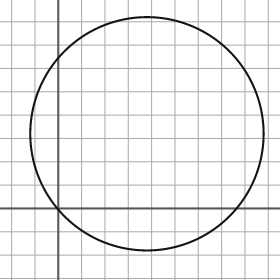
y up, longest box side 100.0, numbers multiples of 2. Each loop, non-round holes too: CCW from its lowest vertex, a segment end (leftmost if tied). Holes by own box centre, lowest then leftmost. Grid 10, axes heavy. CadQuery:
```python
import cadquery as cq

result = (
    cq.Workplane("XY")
    .moveTo(38.0, 32.0)
    .circle(50.0)
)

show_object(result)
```